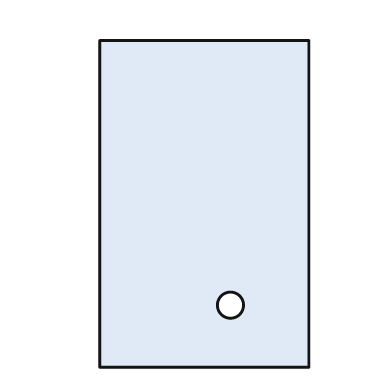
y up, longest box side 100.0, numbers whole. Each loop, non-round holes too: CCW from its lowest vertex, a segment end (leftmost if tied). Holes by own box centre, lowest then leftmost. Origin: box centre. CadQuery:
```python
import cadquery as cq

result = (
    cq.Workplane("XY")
    .moveTo(-32.0, -50.0)
    .lineTo(32.0, -50.0)
    .lineTo(32.0, 50.0)
    .lineTo(-32.0, 50.0)
    .close()
    .moveTo(8.0, -31.0)
    .circle(4.0)
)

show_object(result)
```